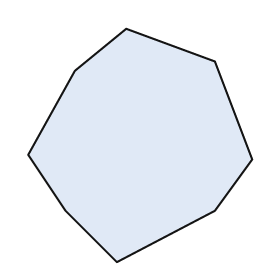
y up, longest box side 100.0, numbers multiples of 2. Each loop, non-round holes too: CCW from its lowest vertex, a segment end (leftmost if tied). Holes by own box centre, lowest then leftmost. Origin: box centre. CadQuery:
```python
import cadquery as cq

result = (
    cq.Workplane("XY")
    .moveTo(-10.0, -50.0)
    .lineTo(32.0, -28.0)
    .lineTo(48.0, -6.0)
    .lineTo(32.0, 36.0)
    .lineTo(-6.0, 50.0)
    .lineTo(-28.0, 32.0)
    .lineTo(-48.0, -4.0)
    .lineTo(-32.0, -28.0)
    .close()
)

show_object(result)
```